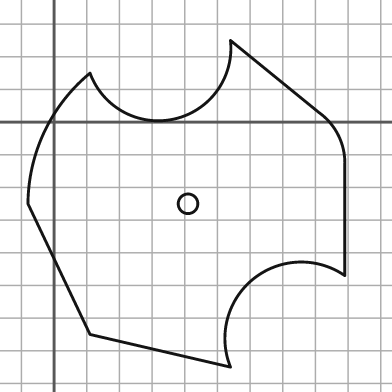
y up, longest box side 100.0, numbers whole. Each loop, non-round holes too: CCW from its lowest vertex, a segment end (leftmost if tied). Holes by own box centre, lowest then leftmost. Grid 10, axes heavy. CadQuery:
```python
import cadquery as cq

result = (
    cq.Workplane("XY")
    .moveTo(54.0, -75.0)
    .threePointArc((61.0, -48.0), (89.0, -47.0))
    .lineTo(89.0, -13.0)
    .threePointArc((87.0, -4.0), (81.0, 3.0))
    .lineTo(54.0, 25.0)
    .threePointArc((37.0, 1.0), (11.0, 15.0))
    .threePointArc((-3.0, -3.0), (-8.0, -25.0))
    .lineTo(11.0, -65.0)
    .close()
    .moveTo(41.0, -25.0)
    .circle(3.0)
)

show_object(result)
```